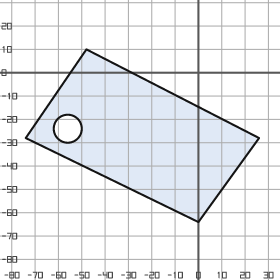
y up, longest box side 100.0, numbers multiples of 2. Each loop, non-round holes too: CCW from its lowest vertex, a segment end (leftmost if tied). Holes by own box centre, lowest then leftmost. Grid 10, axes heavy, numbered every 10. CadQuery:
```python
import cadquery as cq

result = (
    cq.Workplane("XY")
    .moveTo(0.0, -64.0)
    .lineTo(26.0, -28.0)
    .lineTo(-48.0, 10.0)
    .lineTo(-74.0, -28.0)
    .close()
    .moveTo(-56.0, -24.0)
    .circle(6.0)
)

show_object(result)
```